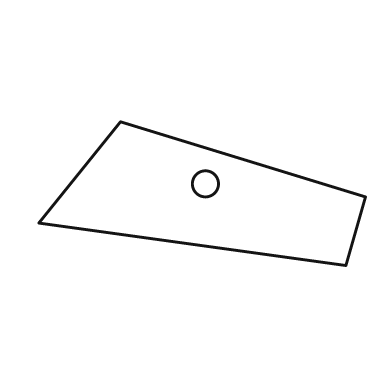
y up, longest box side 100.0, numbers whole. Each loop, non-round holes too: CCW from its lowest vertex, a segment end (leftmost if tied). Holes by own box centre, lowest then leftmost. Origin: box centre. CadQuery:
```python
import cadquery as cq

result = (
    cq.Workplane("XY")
    .moveTo(44.0, -22.0)
    .lineTo(50.0, -1.0)
    .lineTo(-25.0, 22.0)
    .lineTo(-50.0, -9.0)
    .close()
    .moveTo(1.0, 3.0)
    .circle(4.0)
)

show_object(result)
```